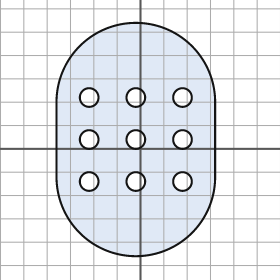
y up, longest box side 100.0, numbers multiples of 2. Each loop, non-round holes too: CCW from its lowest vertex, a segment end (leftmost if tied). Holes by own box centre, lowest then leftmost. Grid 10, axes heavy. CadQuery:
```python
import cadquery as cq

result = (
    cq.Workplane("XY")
    .moveTo(-36.0, -12.0)
    .threePointArc((-2.0, -46.0), (32.0, -12.0))
    .lineTo(32.0, 20.0)
    .threePointArc((-2.0, 54.0), (-36.0, 20.0))
    .close()
    .moveTo(-22.0, -14.0)
    .circle(4.0)
    .moveTo(-2.0, -14.0)
    .circle(4.0)
    .moveTo(18.0, -14.0)
    .circle(4.0)
    .moveTo(-22.0, 4.0)
    .circle(4.0)
    .moveTo(-2.0, 4.0)
    .circle(4.0)
    .moveTo(18.0, 4.0)
    .circle(4.0)
    .moveTo(-22.0, 22.0)
    .circle(4.0)
    .moveTo(-2.0, 22.0)
    .circle(4.0)
    .moveTo(18.0, 22.0)
    .circle(4.0)
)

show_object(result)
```